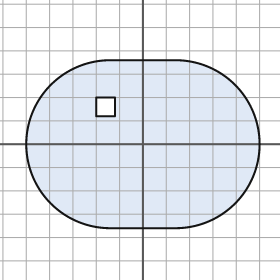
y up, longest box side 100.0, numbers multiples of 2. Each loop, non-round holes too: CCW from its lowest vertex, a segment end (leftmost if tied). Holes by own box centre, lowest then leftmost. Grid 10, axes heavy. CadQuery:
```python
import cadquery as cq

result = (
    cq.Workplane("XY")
    .moveTo(-14.0, -36.0)
    .lineTo(14.0, -36.0)
    .threePointArc((50.0, 0.0), (14.0, 36.0))
    .lineTo(-14.0, 36.0)
    .threePointArc((-50.0, 0.0), (-14.0, -36.0))
    .close()
    .moveTo(-20.0, 12.0)
    .lineTo(-12.0, 12.0)
    .lineTo(-12.0, 20.0)
    .lineTo(-20.0, 20.0)
    .close()
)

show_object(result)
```